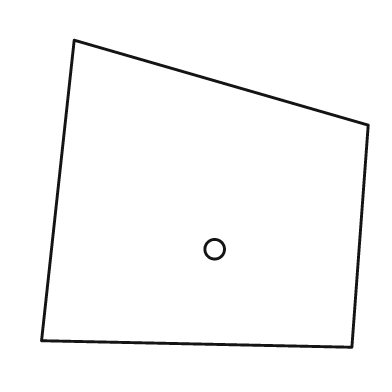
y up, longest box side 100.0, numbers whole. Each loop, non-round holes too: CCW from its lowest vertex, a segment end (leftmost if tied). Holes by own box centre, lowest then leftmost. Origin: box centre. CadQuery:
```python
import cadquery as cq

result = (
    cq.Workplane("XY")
    .moveTo(45.0, -47.0)
    .lineTo(50.0, 21.0)
    .lineTo(-40.0, 47.0)
    .lineTo(-50.0, -45.0)
    .close()
    .moveTo(3.0, -17.0)
    .circle(3.0)
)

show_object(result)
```